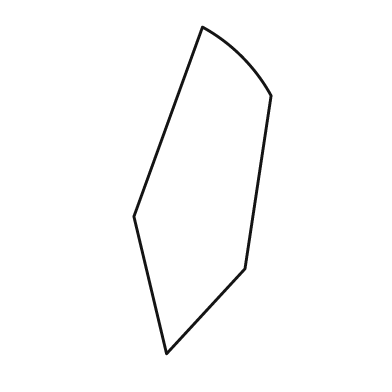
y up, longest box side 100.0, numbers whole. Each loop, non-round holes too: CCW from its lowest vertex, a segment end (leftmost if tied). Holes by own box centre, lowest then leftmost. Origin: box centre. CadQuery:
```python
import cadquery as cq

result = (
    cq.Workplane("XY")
    .moveTo(-11.0, -50.0)
    .lineTo(13.0, -24.0)
    .lineTo(21.0, 29.0)
    .threePointArc((12.0, 41.0), (0.0, 50.0))
    .lineTo(-21.0, -8.0)
    .close()
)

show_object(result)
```